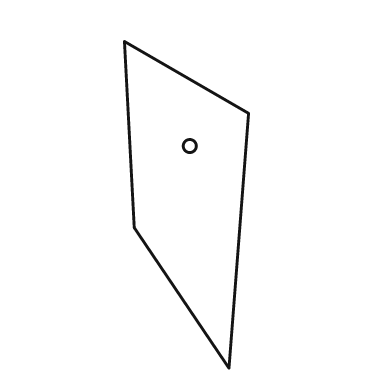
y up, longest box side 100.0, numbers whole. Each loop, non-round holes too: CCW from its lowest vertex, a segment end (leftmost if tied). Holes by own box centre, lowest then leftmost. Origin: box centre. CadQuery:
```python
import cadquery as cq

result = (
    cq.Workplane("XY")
    .moveTo(13.0, -50.0)
    .lineTo(19.0, 28.0)
    .lineTo(-19.0, 50.0)
    .lineTo(-16.0, -7.0)
    .close()
    .moveTo(1.0, 18.0)
    .circle(2.0)
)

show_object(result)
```